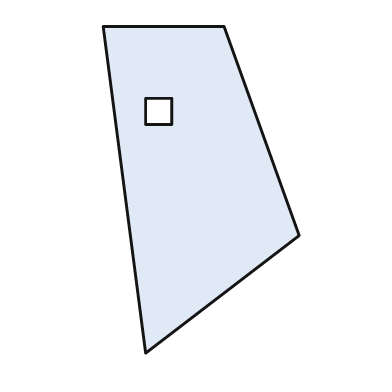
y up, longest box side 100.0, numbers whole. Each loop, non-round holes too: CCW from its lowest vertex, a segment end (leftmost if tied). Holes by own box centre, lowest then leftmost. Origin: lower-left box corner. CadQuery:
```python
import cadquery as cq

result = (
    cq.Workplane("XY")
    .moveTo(13.0, 0.0)
    .lineTo(60.0, 36.0)
    .lineTo(37.0, 100.0)
    .lineTo(0.0, 100.0)
    .close()
    .moveTo(13.0, 70.0)
    .lineTo(21.0, 70.0)
    .lineTo(21.0, 78.0)
    .lineTo(13.0, 78.0)
    .close()
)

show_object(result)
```